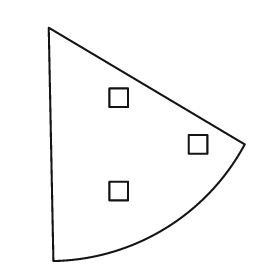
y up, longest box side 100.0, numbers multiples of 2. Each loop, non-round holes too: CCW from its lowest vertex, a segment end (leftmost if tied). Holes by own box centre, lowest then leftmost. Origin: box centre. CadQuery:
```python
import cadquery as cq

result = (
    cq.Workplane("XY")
    .moveTo(-40.0, -50.0)
    .threePointArc((8.0, -36.0), (42.0, 0.0))
    .lineTo(-42.0, 50.0)
    .close()
    .moveTo(-16.0, -24.0)
    .lineTo(-8.0, -24.0)
    .lineTo(-8.0, -16.0)
    .lineTo(-16.0, -16.0)
    .close()
    .moveTo(18.0, -4.0)
    .lineTo(26.0, -4.0)
    .lineTo(26.0, 4.0)
    .lineTo(18.0, 4.0)
    .close()
    .moveTo(-16.0, 16.0)
    .lineTo(-8.0, 16.0)
    .lineTo(-8.0, 24.0)
    .lineTo(-16.0, 24.0)
    .close()
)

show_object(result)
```